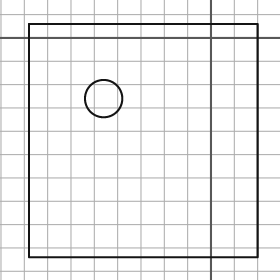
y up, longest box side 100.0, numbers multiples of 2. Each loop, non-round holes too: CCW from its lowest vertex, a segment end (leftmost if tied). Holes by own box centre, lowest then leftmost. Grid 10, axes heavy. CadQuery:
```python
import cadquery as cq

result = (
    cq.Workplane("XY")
    .moveTo(-78.0, -94.0)
    .lineTo(20.0, -94.0)
    .lineTo(20.0, 6.0)
    .lineTo(-78.0, 6.0)
    .close()
    .moveTo(-46.0, -26.0)
    .circle(8.0)
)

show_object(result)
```